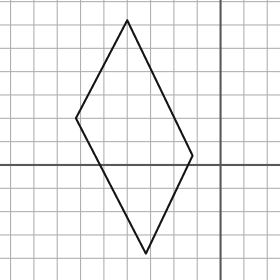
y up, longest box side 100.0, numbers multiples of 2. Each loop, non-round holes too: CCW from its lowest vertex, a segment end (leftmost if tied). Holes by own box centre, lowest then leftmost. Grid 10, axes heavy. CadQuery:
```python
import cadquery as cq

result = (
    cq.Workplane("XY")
    .moveTo(-32.0, -38.0)
    .lineTo(-12.0, 4.0)
    .lineTo(-40.0, 62.0)
    .lineTo(-62.0, 20.0)
    .close()
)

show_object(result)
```